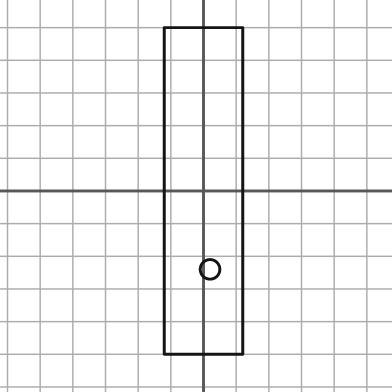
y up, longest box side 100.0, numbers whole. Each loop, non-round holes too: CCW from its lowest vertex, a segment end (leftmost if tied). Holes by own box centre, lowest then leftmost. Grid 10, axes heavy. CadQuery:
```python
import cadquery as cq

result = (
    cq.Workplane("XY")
    .moveTo(-12.0, -50.0)
    .lineTo(12.0, -50.0)
    .lineTo(12.0, 50.0)
    .lineTo(-12.0, 50.0)
    .close()
    .moveTo(2.0, -24.0)
    .circle(3.0)
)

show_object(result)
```